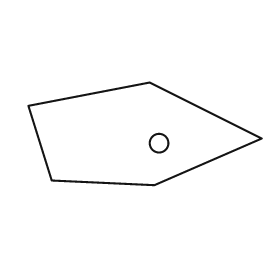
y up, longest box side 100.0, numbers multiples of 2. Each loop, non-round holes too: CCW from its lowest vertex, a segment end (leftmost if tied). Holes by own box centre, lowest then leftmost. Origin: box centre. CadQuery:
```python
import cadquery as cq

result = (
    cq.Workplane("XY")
    .moveTo(4.0, -22.0)
    .lineTo(50.0, -2.0)
    .lineTo(2.0, 22.0)
    .lineTo(-50.0, 12.0)
    .lineTo(-40.0, -20.0)
    .close()
    .moveTo(6.0, -4.0)
    .circle(4.0)
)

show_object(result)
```